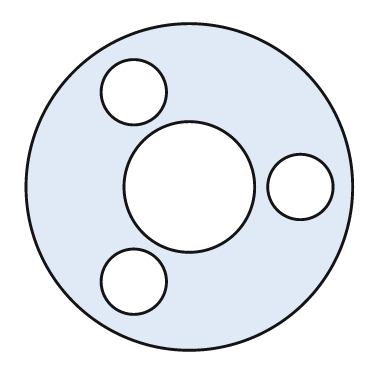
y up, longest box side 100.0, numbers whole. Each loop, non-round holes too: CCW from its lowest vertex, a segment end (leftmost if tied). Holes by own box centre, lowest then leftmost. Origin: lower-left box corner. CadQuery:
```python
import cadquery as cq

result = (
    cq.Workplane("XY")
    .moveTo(50.0, 50.0)
    .circle(50.0)
    .moveTo(33.0, 21.0)
    .circle(10.0)
    .moveTo(50.0, 50.0)
    .circle(20.0)
    .moveTo(84.0, 50.0)
    .circle(10.0)
    .moveTo(33.0, 79.0)
    .circle(10.0)
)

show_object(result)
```